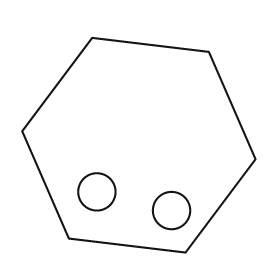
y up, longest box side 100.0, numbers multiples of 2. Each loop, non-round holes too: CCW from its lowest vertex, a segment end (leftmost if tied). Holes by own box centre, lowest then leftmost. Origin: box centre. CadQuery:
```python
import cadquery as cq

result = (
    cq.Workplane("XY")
    .moveTo(20.0, -46.0)
    .lineTo(50.0, -6.0)
    .lineTo(30.0, 40.0)
    .lineTo(-20.0, 46.0)
    .lineTo(-50.0, 6.0)
    .lineTo(-30.0, -40.0)
    .close()
    .moveTo(14.0, -28.0)
    .circle(8.0)
    .moveTo(-18.0, -20.0)
    .circle(8.0)
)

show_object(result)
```